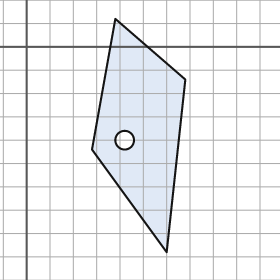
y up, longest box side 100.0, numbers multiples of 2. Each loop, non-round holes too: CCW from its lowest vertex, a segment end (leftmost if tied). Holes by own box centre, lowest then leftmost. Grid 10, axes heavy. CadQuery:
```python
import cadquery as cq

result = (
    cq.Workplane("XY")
    .moveTo(60.0, -88.0)
    .lineTo(68.0, -14.0)
    .lineTo(38.0, 12.0)
    .lineTo(28.0, -44.0)
    .close()
    .moveTo(42.0, -40.0)
    .circle(4.0)
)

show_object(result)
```